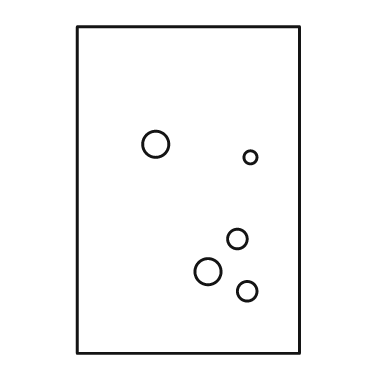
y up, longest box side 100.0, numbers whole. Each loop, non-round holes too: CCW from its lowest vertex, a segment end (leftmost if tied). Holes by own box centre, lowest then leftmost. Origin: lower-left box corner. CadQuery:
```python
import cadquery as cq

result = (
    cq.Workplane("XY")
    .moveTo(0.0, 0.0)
    .lineTo(68.0, 0.0)
    .lineTo(68.0, 100.0)
    .lineTo(0.0, 100.0)
    .close()
    .moveTo(52.0, 19.0)
    .circle(3.0)
    .moveTo(40.0, 25.0)
    .circle(4.0)
    .moveTo(49.0, 35.0)
    .circle(3.0)
    .moveTo(53.0, 60.0)
    .circle(2.0)
    .moveTo(24.0, 64.0)
    .circle(4.0)
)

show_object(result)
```